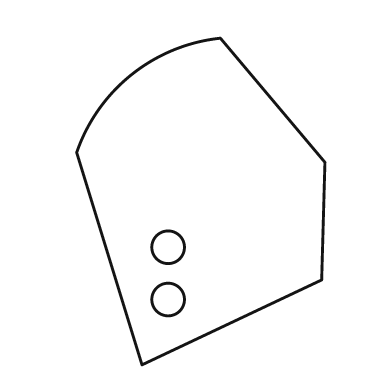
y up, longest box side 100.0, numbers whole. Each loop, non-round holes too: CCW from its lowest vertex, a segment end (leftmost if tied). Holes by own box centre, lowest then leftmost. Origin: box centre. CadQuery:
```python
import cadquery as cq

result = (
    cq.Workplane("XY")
    .moveTo(-18.0, -50.0)
    .lineTo(37.0, -24.0)
    .lineTo(38.0, 12.0)
    .lineTo(6.0, 50.0)
    .threePointArc((-21.0, 39.0), (-38.0, 15.0))
    .close()
    .moveTo(-10.0, -30.0)
    .circle(5.0)
    .moveTo(-10.0, -14.0)
    .circle(5.0)
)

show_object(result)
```